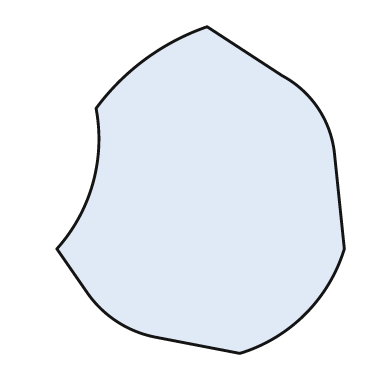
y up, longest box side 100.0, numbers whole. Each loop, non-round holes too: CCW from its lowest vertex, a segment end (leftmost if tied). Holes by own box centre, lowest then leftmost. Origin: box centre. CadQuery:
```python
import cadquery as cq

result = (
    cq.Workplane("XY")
    .moveTo(12.0, -50.0)
    .threePointArc((32.0, -38.0), (44.0, -18.0))
    .lineTo(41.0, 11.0)
    .threePointArc((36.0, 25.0), (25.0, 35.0))
    .lineTo(2.0, 50.0)
    .threePointArc((-17.0, 40.0), (-32.0, 25.0))
    .threePointArc((-33.0, 2.0), (-44.0, -18.0))
    .lineTo(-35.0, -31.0)
    .threePointArc((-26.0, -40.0), (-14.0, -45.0))
    .close()
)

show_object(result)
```